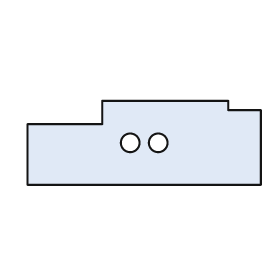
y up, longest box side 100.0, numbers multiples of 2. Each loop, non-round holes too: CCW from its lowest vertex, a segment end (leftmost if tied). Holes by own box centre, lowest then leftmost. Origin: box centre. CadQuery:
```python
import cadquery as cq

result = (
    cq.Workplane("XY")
    .moveTo(-50.0, -18.0)
    .lineTo(50.0, -18.0)
    .lineTo(50.0, 14.0)
    .lineTo(36.0, 14.0)
    .lineTo(36.0, 18.0)
    .lineTo(-18.0, 18.0)
    .lineTo(-18.0, 8.0)
    .lineTo(-50.0, 8.0)
    .close()
    .moveTo(-6.0, 0.0)
    .circle(4.0)
    .moveTo(6.0, 0.0)
    .circle(4.0)
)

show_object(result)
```